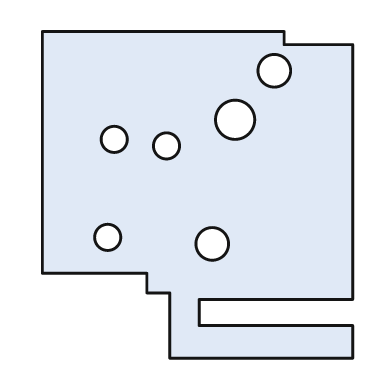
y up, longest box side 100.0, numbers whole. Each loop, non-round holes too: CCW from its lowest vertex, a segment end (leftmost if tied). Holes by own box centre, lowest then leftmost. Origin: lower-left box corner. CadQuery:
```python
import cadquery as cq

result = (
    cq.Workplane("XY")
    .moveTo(39.0, 0.0)
    .lineTo(95.0, 0.0)
    .lineTo(95.0, 10.0)
    .lineTo(48.0, 10.0)
    .lineTo(48.0, 18.0)
    .lineTo(95.0, 18.0)
    .lineTo(95.0, 96.0)
    .lineTo(74.0, 96.0)
    .lineTo(74.0, 100.0)
    .lineTo(0.0, 100.0)
    .lineTo(0.0, 26.0)
    .lineTo(32.0, 26.0)
    .lineTo(32.0, 20.0)
    .lineTo(39.0, 20.0)
    .close()
    .moveTo(52.0, 35.0)
    .circle(5.0)
    .moveTo(20.0, 37.0)
    .circle(4.0)
    .moveTo(38.0, 65.0)
    .circle(4.0)
    .moveTo(22.0, 67.0)
    .circle(4.0)
    .moveTo(59.0, 73.0)
    .circle(6.0)
    .moveTo(71.0, 88.0)
    .circle(5.0)
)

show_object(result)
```